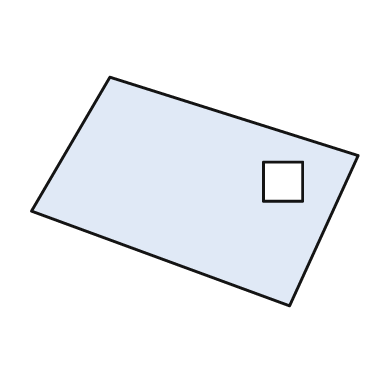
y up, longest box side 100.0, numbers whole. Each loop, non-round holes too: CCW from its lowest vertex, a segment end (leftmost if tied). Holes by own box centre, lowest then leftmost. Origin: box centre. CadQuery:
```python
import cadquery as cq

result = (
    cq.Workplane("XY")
    .moveTo(29.0, -35.0)
    .lineTo(50.0, 11.0)
    .lineTo(-26.0, 35.0)
    .lineTo(-50.0, -6.0)
    .close()
    .moveTo(21.0, -3.0)
    .lineTo(33.0, -3.0)
    .lineTo(33.0, 9.0)
    .lineTo(21.0, 9.0)
    .close()
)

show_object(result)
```